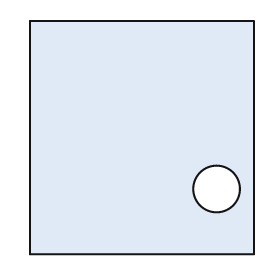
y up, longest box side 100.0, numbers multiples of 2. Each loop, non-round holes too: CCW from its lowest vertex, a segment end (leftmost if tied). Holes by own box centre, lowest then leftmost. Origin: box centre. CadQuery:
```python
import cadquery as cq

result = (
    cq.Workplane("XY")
    .moveTo(-48.0, -50.0)
    .lineTo(48.0, -50.0)
    .lineTo(48.0, 50.0)
    .lineTo(-48.0, 50.0)
    .close()
    .moveTo(32.0, -22.0)
    .circle(10.0)
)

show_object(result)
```